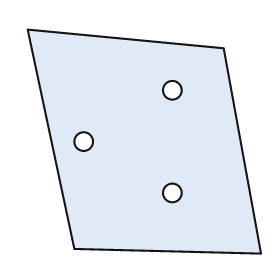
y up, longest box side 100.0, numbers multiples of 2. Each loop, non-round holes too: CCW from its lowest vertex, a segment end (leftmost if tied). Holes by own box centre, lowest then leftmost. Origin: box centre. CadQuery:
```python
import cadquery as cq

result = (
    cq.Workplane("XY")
    .moveTo(50.0, -48.0)
    .lineTo(34.0, 40.0)
    .lineTo(-50.0, 48.0)
    .lineTo(-30.0, -46.0)
    .close()
    .moveTo(12.0, -22.0)
    .circle(4.0)
    .moveTo(-26.0, 0.0)
    .circle(4.0)
    .moveTo(12.0, 22.0)
    .circle(4.0)
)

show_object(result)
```